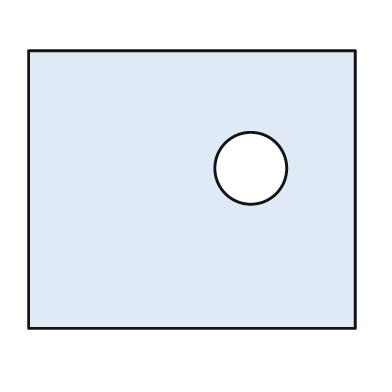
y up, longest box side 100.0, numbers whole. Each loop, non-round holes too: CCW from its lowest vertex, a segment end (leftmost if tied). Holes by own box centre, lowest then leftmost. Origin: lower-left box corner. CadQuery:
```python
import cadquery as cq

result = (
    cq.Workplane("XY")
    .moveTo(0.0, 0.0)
    .lineTo(100.0, 0.0)
    .lineTo(100.0, 85.0)
    .lineTo(0.0, 85.0)
    .close()
    .moveTo(68.0, 49.0)
    .circle(11.0)
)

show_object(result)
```